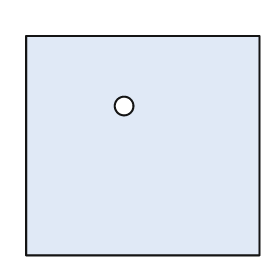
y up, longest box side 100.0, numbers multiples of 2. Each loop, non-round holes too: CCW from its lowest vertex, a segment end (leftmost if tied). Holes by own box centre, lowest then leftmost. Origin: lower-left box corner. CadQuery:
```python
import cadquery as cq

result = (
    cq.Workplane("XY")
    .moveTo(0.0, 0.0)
    .lineTo(100.0, 0.0)
    .lineTo(100.0, 94.0)
    .lineTo(0.0, 94.0)
    .close()
    .moveTo(42.0, 64.0)
    .circle(4.0)
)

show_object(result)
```